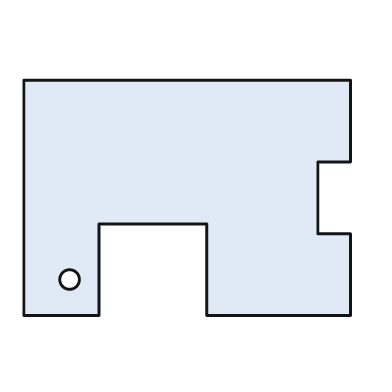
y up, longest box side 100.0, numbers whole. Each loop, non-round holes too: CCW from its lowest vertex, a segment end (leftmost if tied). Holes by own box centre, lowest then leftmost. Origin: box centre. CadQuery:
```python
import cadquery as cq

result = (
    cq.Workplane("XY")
    .moveTo(-50.0, -36.0)
    .lineTo(-27.0, -36.0)
    .lineTo(-27.0, -8.0)
    .lineTo(6.0, -8.0)
    .lineTo(6.0, -36.0)
    .lineTo(50.0, -36.0)
    .lineTo(50.0, -11.0)
    .lineTo(40.0, -11.0)
    .lineTo(40.0, 11.0)
    .lineTo(50.0, 11.0)
    .lineTo(50.0, 36.0)
    .lineTo(-50.0, 36.0)
    .close()
    .moveTo(-36.0, -25.0)
    .circle(3.0)
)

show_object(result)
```